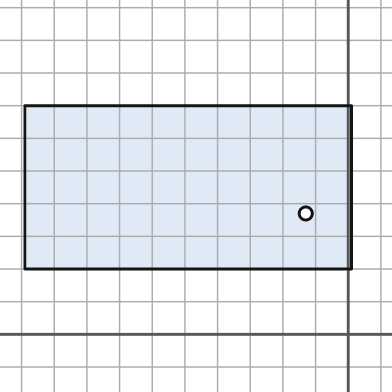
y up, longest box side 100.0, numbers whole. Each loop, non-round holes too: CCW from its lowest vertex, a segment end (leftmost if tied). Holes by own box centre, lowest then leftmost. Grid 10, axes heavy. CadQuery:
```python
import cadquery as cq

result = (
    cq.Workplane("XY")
    .moveTo(-99.0, 20.0)
    .lineTo(1.0, 20.0)
    .lineTo(1.0, 70.0)
    .lineTo(-99.0, 70.0)
    .close()
    .moveTo(-13.0, 37.0)
    .circle(2.0)
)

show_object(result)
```